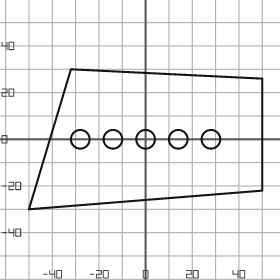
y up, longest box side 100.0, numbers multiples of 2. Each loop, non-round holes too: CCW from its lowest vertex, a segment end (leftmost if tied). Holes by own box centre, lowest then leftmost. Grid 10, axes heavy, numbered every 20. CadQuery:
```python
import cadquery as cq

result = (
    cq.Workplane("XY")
    .moveTo(-50.0, -30.0)
    .lineTo(50.0, -22.0)
    .lineTo(50.0, 26.0)
    .lineTo(-32.0, 30.0)
    .close()
    .moveTo(-28.0, 0.0)
    .circle(4.0)
    .moveTo(-14.0, 0.0)
    .circle(4.0)
    .moveTo(0.0, 0.0)
    .circle(4.0)
    .moveTo(14.0, 0.0)
    .circle(4.0)
    .moveTo(28.0, 0.0)
    .circle(4.0)
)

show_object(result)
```